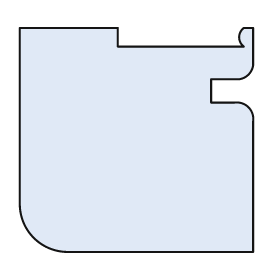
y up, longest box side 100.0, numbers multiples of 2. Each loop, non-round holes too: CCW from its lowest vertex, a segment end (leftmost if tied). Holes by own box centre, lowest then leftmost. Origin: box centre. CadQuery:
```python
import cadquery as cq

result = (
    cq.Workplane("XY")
    .moveTo(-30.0, -48.0)
    .lineTo(50.0, -48.0)
    .lineTo(50.0, 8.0)
    .threePointArc((48.0, 14.0), (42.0, 16.0))
    .lineTo(32.0, 16.0)
    .lineTo(32.0, 26.0)
    .lineTo(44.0, 26.0)
    .threePointArc((48.0, 28.0), (50.0, 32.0))
    .lineTo(50.0, 48.0)
    .lineTo(46.0, 48.0)
    .threePointArc((44.0, 44.0), (46.0, 40.0))
    .lineTo(-8.0, 40.0)
    .lineTo(-8.0, 48.0)
    .lineTo(-50.0, 48.0)
    .lineTo(-50.0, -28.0)
    .threePointArc((-44.0, -42.0), (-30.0, -48.0))
    .close()
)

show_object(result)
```